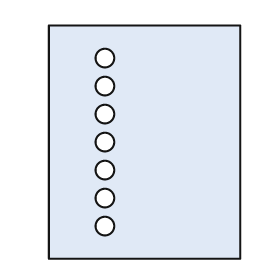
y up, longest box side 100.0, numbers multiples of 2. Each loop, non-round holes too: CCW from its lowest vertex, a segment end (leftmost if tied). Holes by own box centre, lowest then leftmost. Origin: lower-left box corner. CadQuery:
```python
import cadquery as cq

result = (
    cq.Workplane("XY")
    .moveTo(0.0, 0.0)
    .lineTo(82.0, 0.0)
    .lineTo(82.0, 100.0)
    .lineTo(0.0, 100.0)
    .close()
    .moveTo(24.0, 14.0)
    .circle(4.0)
    .moveTo(24.0, 26.0)
    .circle(4.0)
    .moveTo(24.0, 38.0)
    .circle(4.0)
    .moveTo(24.0, 50.0)
    .circle(4.0)
    .moveTo(24.0, 62.0)
    .circle(4.0)
    .moveTo(24.0, 74.0)
    .circle(4.0)
    .moveTo(24.0, 86.0)
    .circle(4.0)
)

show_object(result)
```